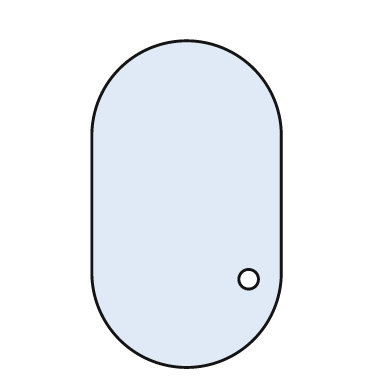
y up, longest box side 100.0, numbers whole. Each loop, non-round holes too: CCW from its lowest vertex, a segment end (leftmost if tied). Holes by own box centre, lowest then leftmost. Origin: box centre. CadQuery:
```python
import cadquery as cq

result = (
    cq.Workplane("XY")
    .moveTo(-29.0, -21.0)
    .threePointArc((0.0, -50.0), (29.0, -21.0))
    .lineTo(29.0, 21.0)
    .threePointArc((0.0, 50.0), (-29.0, 21.0))
    .close()
    .moveTo(19.0, -23.0)
    .circle(3.0)
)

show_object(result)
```